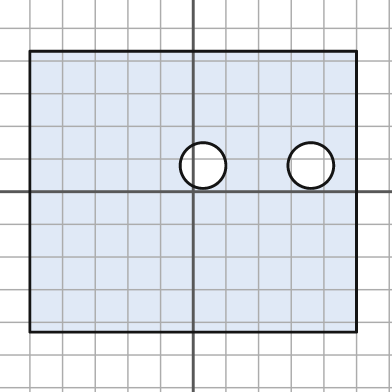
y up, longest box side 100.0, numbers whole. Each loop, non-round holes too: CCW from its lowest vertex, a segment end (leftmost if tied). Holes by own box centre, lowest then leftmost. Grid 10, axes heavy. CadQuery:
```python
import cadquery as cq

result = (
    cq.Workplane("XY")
    .moveTo(-50.0, -43.0)
    .lineTo(50.0, -43.0)
    .lineTo(50.0, 43.0)
    .lineTo(-50.0, 43.0)
    .close()
    .moveTo(3.0, 8.0)
    .circle(7.0)
    .moveTo(36.0, 8.0)
    .circle(7.0)
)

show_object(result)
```